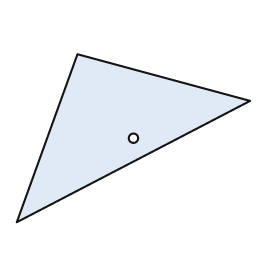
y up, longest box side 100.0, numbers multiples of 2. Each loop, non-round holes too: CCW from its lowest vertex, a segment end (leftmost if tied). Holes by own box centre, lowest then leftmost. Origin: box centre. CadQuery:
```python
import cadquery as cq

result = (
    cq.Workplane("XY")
    .moveTo(-50.0, -36.0)
    .lineTo(50.0, 16.0)
    .lineTo(-24.0, 36.0)
    .close()
    .moveTo(0.0, 0.0)
    .circle(2.0)
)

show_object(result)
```